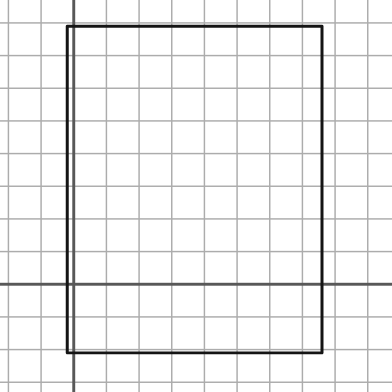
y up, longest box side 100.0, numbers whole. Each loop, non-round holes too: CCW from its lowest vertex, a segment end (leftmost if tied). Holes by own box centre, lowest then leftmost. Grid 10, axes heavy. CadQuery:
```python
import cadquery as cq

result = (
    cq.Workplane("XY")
    .moveTo(-2.0, -21.0)
    .lineTo(76.0, -21.0)
    .lineTo(76.0, 79.0)
    .lineTo(-2.0, 79.0)
    .close()
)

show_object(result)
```